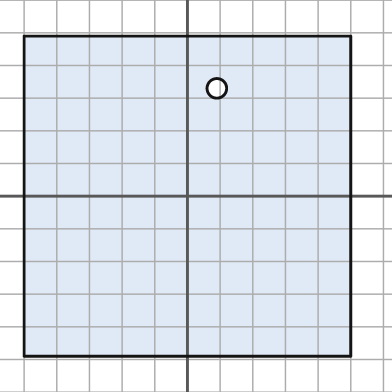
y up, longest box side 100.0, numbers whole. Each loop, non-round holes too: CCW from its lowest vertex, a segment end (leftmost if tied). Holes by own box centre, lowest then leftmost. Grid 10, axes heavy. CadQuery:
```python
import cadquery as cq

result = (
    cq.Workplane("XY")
    .moveTo(-50.0, -49.0)
    .lineTo(50.0, -49.0)
    .lineTo(50.0, 49.0)
    .lineTo(-50.0, 49.0)
    .close()
    .moveTo(9.0, 33.0)
    .circle(3.0)
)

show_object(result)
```